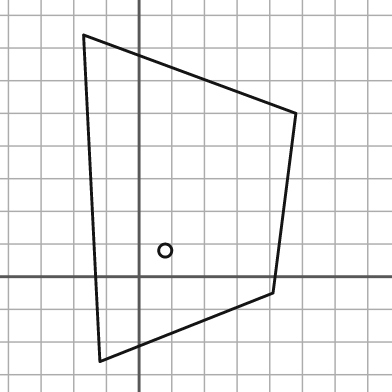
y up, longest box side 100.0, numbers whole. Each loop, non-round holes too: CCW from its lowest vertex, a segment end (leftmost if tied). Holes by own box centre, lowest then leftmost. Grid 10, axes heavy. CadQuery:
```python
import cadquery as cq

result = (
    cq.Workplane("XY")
    .moveTo(-12.0, -26.0)
    .lineTo(41.0, -5.0)
    .lineTo(48.0, 50.0)
    .lineTo(-17.0, 74.0)
    .close()
    .moveTo(8.0, 8.0)
    .circle(2.0)
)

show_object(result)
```